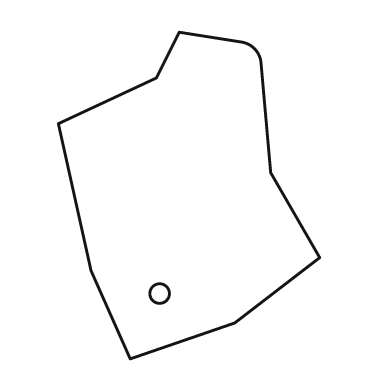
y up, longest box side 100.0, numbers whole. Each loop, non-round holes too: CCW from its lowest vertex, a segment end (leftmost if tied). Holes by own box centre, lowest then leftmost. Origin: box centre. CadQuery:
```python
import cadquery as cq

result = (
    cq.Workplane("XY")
    .moveTo(-18.0, -50.0)
    .lineTo(14.0, -39.0)
    .lineTo(40.0, -19.0)
    .lineTo(25.0, 7.0)
    .lineTo(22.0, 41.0)
    .threePointArc((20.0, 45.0), (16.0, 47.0))
    .lineTo(-3.0, 50.0)
    .lineTo(-10.0, 36.0)
    .lineTo(-40.0, 22.0)
    .lineTo(-30.0, -23.0)
    .close()
    .moveTo(-9.0, -30.0)
    .circle(3.0)
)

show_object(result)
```